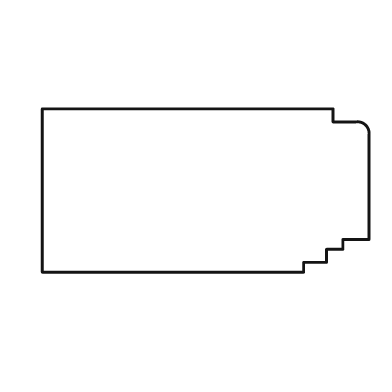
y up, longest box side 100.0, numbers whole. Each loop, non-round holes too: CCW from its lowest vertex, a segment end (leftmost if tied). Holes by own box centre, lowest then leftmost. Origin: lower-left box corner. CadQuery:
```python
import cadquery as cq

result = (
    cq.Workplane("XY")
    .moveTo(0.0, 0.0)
    .lineTo(80.0, 0.0)
    .lineTo(80.0, 3.0)
    .lineTo(87.0, 3.0)
    .lineTo(87.0, 7.0)
    .lineTo(92.0, 7.0)
    .lineTo(92.0, 10.0)
    .lineTo(100.0, 10.0)
    .lineTo(100.0, 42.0)
    .threePointArc((99.0, 45.0), (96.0, 46.0))
    .lineTo(89.0, 46.0)
    .lineTo(89.0, 50.0)
    .lineTo(0.0, 50.0)
    .close()
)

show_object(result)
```